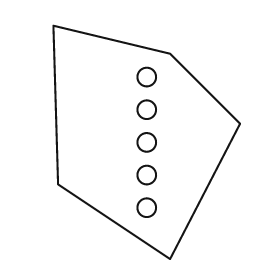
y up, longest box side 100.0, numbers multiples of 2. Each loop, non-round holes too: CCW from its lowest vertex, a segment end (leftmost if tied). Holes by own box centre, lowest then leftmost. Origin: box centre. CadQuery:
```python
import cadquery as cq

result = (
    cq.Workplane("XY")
    .moveTo(10.0, -50.0)
    .lineTo(40.0, 8.0)
    .lineTo(10.0, 38.0)
    .lineTo(-40.0, 50.0)
    .lineTo(-38.0, -18.0)
    .close()
    .moveTo(0.0, -28.0)
    .circle(4.0)
    .moveTo(0.0, -14.0)
    .circle(4.0)
    .moveTo(0.0, 0.0)
    .circle(4.0)
    .moveTo(0.0, 14.0)
    .circle(4.0)
    .moveTo(0.0, 28.0)
    .circle(4.0)
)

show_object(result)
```